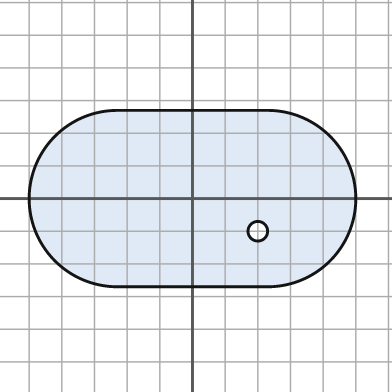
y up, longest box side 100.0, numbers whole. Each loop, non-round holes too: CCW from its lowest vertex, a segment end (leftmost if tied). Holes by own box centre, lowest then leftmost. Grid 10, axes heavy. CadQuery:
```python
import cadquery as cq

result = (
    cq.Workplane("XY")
    .moveTo(-23.0, -27.0)
    .lineTo(23.0, -27.0)
    .threePointArc((50.0, 0.0), (23.0, 27.0))
    .lineTo(-23.0, 27.0)
    .threePointArc((-50.0, 0.0), (-23.0, -27.0))
    .close()
    .moveTo(20.0, -10.0)
    .circle(3.0)
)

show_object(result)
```